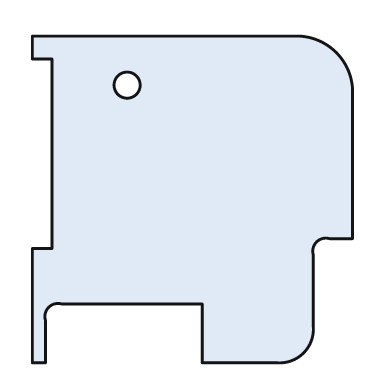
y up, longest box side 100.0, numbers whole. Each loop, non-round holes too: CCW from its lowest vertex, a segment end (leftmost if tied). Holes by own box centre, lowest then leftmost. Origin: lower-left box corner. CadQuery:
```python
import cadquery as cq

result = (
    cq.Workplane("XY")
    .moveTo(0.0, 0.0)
    .lineTo(4.0, 0.0)
    .lineTo(4.0, 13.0)
    .threePointArc((5.0, 17.0), (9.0, 18.0))
    .lineTo(52.0, 18.0)
    .lineTo(52.0, 0.0)
    .lineTo(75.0, 0.0)
    .threePointArc((83.0, 3.0), (86.0, 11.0))
    .lineTo(86.0, 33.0)
    .threePointArc((87.0, 37.0), (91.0, 38.0))
    .lineTo(98.0, 38.0)
    .lineTo(98.0, 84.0)
    .threePointArc((93.0, 95.0), (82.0, 100.0))
    .lineTo(0.0, 100.0)
    .lineTo(0.0, 93.0)
    .lineTo(6.0, 93.0)
    .lineTo(6.0, 35.0)
    .lineTo(0.0, 35.0)
    .close()
    .moveTo(29.0, 85.0)
    .circle(4.0)
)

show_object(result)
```